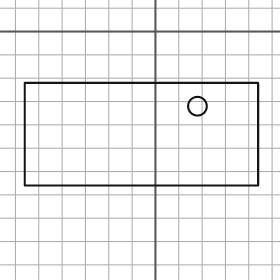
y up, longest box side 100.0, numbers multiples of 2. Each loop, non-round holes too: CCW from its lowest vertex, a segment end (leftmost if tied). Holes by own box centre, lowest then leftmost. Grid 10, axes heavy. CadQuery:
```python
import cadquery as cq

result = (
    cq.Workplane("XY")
    .moveTo(-56.0, -66.0)
    .lineTo(44.0, -66.0)
    .lineTo(44.0, -22.0)
    .lineTo(-56.0, -22.0)
    .close()
    .moveTo(18.0, -32.0)
    .circle(4.0)
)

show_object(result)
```